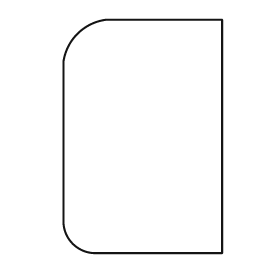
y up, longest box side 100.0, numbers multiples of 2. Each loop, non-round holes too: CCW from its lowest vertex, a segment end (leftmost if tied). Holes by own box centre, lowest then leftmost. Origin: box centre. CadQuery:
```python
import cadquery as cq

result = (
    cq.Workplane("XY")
    .moveTo(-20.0, -50.0)
    .lineTo(34.0, -50.0)
    .lineTo(34.0, 50.0)
    .lineTo(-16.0, 50.0)
    .threePointArc((-28.0, 44.0), (-34.0, 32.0))
    .lineTo(-34.0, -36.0)
    .threePointArc((-30.0, -46.0), (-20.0, -50.0))
    .close()
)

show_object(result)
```